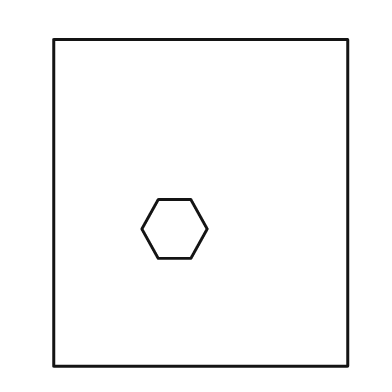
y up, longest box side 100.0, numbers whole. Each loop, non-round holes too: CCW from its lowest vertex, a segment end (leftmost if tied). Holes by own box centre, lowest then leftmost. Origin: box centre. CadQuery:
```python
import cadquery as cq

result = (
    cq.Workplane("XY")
    .moveTo(-45.0, -50.0)
    .lineTo(45.0, -50.0)
    .lineTo(45.0, 50.0)
    .lineTo(-45.0, 50.0)
    .close()
    .moveTo(-13.0, -17.0)
    .lineTo(-3.0, -17.0)
    .lineTo(2.0, -8.0)
    .lineTo(-3.0, 1.0)
    .lineTo(-13.0, 1.0)
    .lineTo(-18.0, -8.0)
    .close()
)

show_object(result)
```